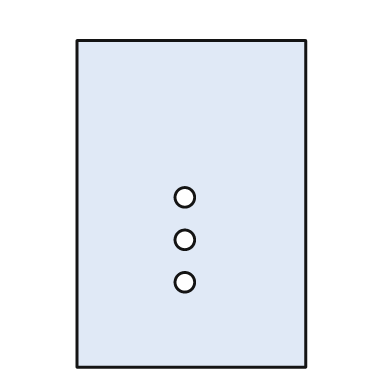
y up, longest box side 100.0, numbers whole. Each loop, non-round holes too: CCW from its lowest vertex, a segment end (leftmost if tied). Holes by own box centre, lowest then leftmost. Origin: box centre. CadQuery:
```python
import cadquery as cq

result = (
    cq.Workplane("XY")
    .moveTo(-35.0, -50.0)
    .lineTo(35.0, -50.0)
    .lineTo(35.0, 50.0)
    .lineTo(-35.0, 50.0)
    .close()
    .moveTo(-2.0, -24.0)
    .circle(3.0)
    .moveTo(-2.0, -11.0)
    .circle(3.0)
    .moveTo(-2.0, 2.0)
    .circle(3.0)
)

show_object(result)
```